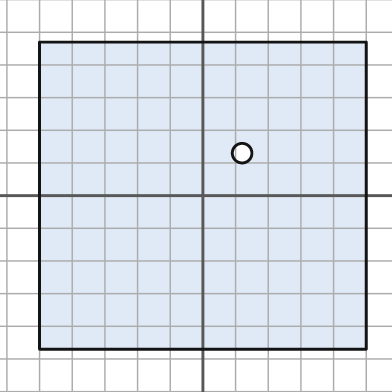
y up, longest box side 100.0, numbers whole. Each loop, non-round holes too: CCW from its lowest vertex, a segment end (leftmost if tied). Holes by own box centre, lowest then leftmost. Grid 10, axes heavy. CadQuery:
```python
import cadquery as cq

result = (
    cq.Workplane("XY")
    .moveTo(-50.0, -47.0)
    .lineTo(50.0, -47.0)
    .lineTo(50.0, 47.0)
    .lineTo(-50.0, 47.0)
    .close()
    .moveTo(12.0, 13.0)
    .circle(3.0)
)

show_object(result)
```